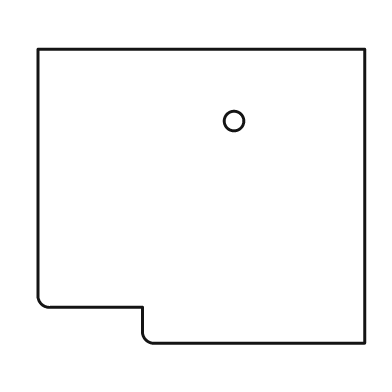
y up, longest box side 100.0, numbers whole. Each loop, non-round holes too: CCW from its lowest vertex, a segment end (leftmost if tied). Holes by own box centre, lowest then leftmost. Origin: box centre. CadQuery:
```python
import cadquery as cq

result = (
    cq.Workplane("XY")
    .moveTo(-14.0, -45.0)
    .lineTo(50.0, -45.0)
    .lineTo(50.0, 45.0)
    .lineTo(-50.0, 45.0)
    .lineTo(-50.0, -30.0)
    .threePointArc((-49.0, -33.0), (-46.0, -34.0))
    .lineTo(-18.0, -34.0)
    .lineTo(-18.0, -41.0)
    .threePointArc((-17.0, -44.0), (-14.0, -45.0))
    .close()
    .moveTo(10.0, 23.0)
    .circle(3.0)
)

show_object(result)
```